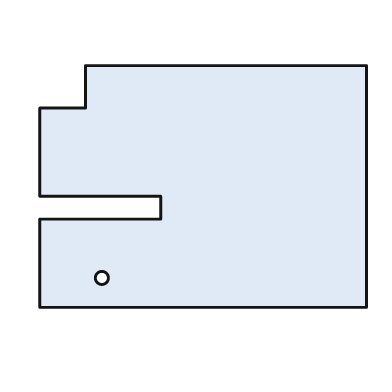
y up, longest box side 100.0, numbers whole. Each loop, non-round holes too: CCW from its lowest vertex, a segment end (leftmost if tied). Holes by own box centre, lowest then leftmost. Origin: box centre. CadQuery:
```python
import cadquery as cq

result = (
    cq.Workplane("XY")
    .moveTo(-50.0, -37.0)
    .lineTo(50.0, -37.0)
    .lineTo(50.0, 37.0)
    .lineTo(-36.0, 37.0)
    .lineTo(-36.0, 24.0)
    .lineTo(-50.0, 24.0)
    .lineTo(-50.0, -3.0)
    .lineTo(-13.0, -3.0)
    .lineTo(-13.0, -10.0)
    .lineTo(-50.0, -10.0)
    .close()
    .moveTo(-31.0, -28.0)
    .circle(2.0)
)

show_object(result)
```